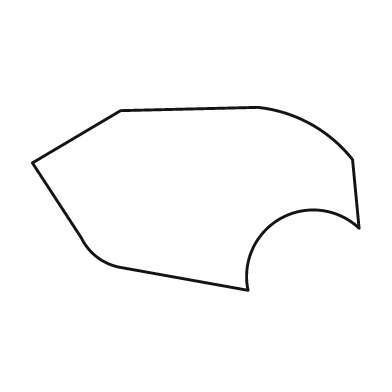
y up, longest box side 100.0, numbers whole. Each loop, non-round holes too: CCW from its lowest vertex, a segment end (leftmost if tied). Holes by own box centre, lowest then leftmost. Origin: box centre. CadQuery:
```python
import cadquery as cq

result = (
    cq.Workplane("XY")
    .moveTo(16.0, -28.0)
    .threePointArc((26.0, -6.0), (50.0, -9.0))
    .lineTo(48.0, 12.0)
    .threePointArc((35.0, 23.0), (19.0, 28.0))
    .lineTo(-23.0, 27.0)
    .lineTo(-50.0, 11.0)
    .lineTo(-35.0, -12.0)
    .threePointArc((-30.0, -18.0), (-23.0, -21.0))
    .close()
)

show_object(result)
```